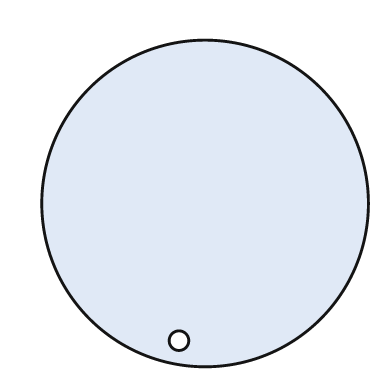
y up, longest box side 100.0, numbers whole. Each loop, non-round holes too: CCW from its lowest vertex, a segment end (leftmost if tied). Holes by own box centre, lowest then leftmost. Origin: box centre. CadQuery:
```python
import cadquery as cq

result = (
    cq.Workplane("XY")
    .moveTo(0.0, 0.0)
    .circle(50.0)
    .moveTo(-8.0, -42.0)
    .circle(3.0)
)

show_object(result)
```